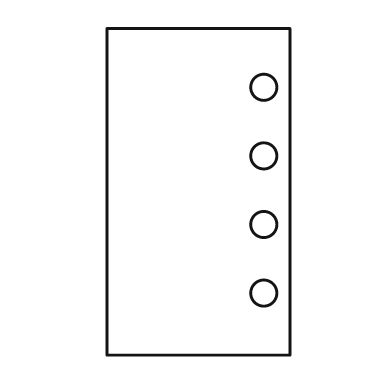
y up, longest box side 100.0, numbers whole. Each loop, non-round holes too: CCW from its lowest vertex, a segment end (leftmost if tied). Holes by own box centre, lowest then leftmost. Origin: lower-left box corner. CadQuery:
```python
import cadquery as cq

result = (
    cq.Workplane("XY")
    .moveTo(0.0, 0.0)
    .lineTo(56.0, 0.0)
    .lineTo(56.0, 100.0)
    .lineTo(0.0, 100.0)
    .close()
    .moveTo(48.0, 19.0)
    .circle(4.0)
    .moveTo(48.0, 40.0)
    .circle(4.0)
    .moveTo(48.0, 61.0)
    .circle(4.0)
    .moveTo(48.0, 82.0)
    .circle(4.0)
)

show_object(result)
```